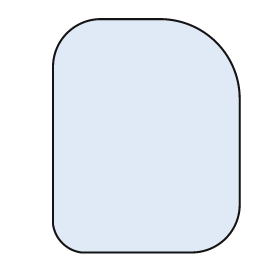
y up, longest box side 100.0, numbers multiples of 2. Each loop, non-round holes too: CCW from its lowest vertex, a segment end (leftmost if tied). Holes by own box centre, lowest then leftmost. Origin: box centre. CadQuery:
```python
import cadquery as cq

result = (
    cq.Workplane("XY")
    .moveTo(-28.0, -50.0)
    .lineTo(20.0, -50.0)
    .threePointArc((34.0, -44.0), (40.0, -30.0))
    .lineTo(40.0, 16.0)
    .threePointArc((30.0, 40.0), (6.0, 50.0))
    .lineTo(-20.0, 50.0)
    .threePointArc((-34.0, 44.0), (-40.0, 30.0))
    .lineTo(-40.0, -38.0)
    .threePointArc((-36.0, -46.0), (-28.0, -50.0))
    .close()
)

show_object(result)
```